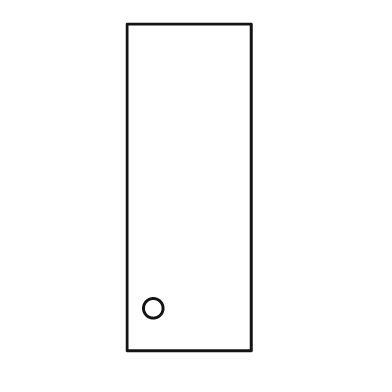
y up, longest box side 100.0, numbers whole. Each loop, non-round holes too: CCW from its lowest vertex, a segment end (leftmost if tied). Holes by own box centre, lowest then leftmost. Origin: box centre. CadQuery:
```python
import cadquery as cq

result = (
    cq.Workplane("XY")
    .moveTo(-19.0, -50.0)
    .lineTo(19.0, -50.0)
    .lineTo(19.0, 50.0)
    .lineTo(-19.0, 50.0)
    .close()
    .moveTo(-11.0, -37.0)
    .circle(3.0)
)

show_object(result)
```